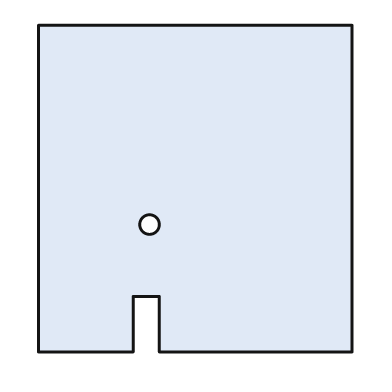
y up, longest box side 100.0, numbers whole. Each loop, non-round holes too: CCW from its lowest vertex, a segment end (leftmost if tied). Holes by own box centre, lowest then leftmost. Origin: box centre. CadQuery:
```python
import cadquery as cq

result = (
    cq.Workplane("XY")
    .moveTo(-48.0, -50.0)
    .lineTo(-19.0, -50.0)
    .lineTo(-19.0, -33.0)
    .lineTo(-11.0, -33.0)
    .lineTo(-11.0, -50.0)
    .lineTo(48.0, -50.0)
    .lineTo(48.0, 50.0)
    .lineTo(-48.0, 50.0)
    .close()
    .moveTo(-14.0, -11.0)
    .circle(3.0)
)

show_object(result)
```